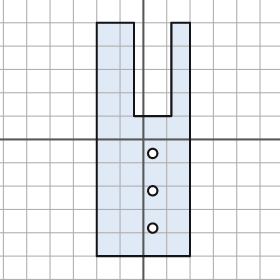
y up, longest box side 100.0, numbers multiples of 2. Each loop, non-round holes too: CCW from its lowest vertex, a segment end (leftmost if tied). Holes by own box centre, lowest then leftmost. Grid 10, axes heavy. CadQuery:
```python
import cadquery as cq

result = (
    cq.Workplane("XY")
    .moveTo(-20.0, -50.0)
    .lineTo(20.0, -50.0)
    .lineTo(20.0, 50.0)
    .lineTo(12.0, 50.0)
    .lineTo(12.0, 10.0)
    .lineTo(-4.0, 10.0)
    .lineTo(-4.0, 50.0)
    .lineTo(-20.0, 50.0)
    .close()
    .moveTo(4.0, -38.0)
    .circle(2.0)
    .moveTo(4.0, -22.0)
    .circle(2.0)
    .moveTo(4.0, -6.0)
    .circle(2.0)
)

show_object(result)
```